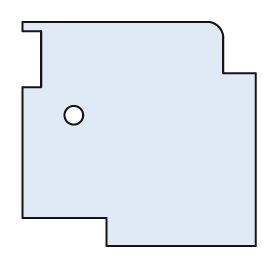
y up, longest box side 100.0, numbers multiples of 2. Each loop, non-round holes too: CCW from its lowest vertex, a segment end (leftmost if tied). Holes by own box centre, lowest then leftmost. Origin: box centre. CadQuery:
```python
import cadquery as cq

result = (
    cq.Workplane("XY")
    .moveTo(-14.0, -48.0)
    .lineTo(50.0, -48.0)
    .lineTo(50.0, 26.0)
    .lineTo(36.0, 26.0)
    .lineTo(36.0, 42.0)
    .threePointArc((34.0, 46.0), (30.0, 48.0))
    .lineTo(-50.0, 48.0)
    .lineTo(-50.0, 44.0)
    .lineTo(-42.0, 44.0)
    .lineTo(-42.0, 20.0)
    .lineTo(-50.0, 20.0)
    .lineTo(-50.0, -36.0)
    .lineTo(-14.0, -36.0)
    .close()
    .moveTo(-28.0, 8.0)
    .circle(4.0)
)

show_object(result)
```